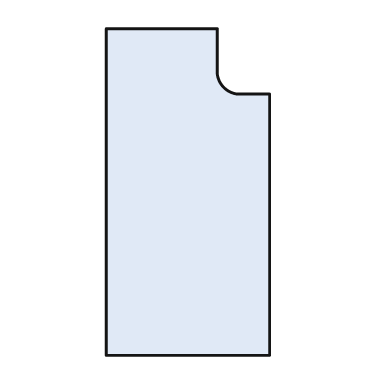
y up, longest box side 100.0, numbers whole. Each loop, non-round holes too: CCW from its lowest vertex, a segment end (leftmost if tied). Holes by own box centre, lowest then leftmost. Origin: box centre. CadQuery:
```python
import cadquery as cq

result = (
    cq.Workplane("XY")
    .moveTo(-25.0, -50.0)
    .lineTo(25.0, -50.0)
    .lineTo(25.0, 30.0)
    .lineTo(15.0, 30.0)
    .threePointArc((11.0, 32.0), (9.0, 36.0))
    .lineTo(9.0, 50.0)
    .lineTo(-25.0, 50.0)
    .close()
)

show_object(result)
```